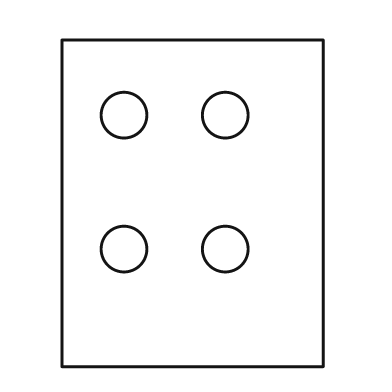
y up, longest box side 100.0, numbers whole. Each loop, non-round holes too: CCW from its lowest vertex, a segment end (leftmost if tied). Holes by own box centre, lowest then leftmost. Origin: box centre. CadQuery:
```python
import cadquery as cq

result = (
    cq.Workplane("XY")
    .moveTo(-40.0, -50.0)
    .lineTo(40.0, -50.0)
    .lineTo(40.0, 50.0)
    .lineTo(-40.0, 50.0)
    .close()
    .moveTo(-21.0, -14.0)
    .circle(7.0)
    .moveTo(10.0, -14.0)
    .circle(7.0)
    .moveTo(-21.0, 27.0)
    .circle(7.0)
    .moveTo(10.0, 27.0)
    .circle(7.0)
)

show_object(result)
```